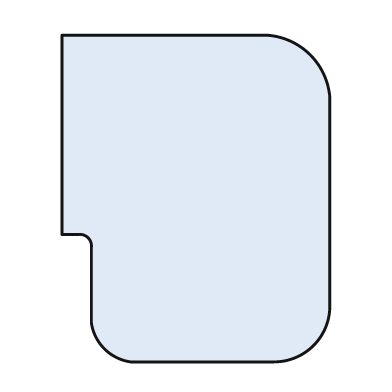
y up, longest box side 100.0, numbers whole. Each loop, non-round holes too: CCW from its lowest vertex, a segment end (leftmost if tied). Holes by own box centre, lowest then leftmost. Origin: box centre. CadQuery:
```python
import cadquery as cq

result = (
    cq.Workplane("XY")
    .moveTo(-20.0, -50.0)
    .lineTo(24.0, -50.0)
    .threePointArc((36.0, -45.0), (41.0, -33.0))
    .lineTo(41.0, 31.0)
    .threePointArc((35.0, 44.0), (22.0, 50.0))
    .lineTo(-41.0, 50.0)
    .lineTo(-41.0, -11.0)
    .lineTo(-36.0, -11.0)
    .threePointArc((-33.0, -12.0), (-32.0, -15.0))
    .lineTo(-32.0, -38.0)
    .threePointArc((-28.0, -46.0), (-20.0, -50.0))
    .close()
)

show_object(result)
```